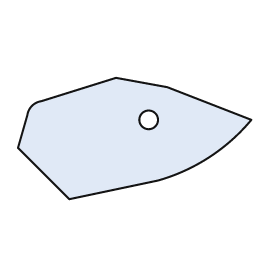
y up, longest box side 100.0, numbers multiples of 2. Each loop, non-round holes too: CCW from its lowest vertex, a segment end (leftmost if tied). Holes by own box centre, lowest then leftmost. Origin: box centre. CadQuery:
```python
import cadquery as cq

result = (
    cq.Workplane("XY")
    .moveTo(-28.0, -26.0)
    .lineTo(10.0, -18.0)
    .threePointArc((32.0, -8.0), (50.0, 8.0))
    .lineTo(14.0, 22.0)
    .lineTo(-8.0, 26.0)
    .lineTo(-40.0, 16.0)
    .threePointArc((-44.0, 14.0), (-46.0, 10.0))
    .lineTo(-50.0, -4.0)
    .close()
    .moveTo(6.0, 8.0)
    .circle(4.0)
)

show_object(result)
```